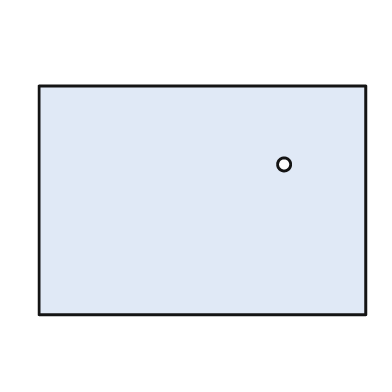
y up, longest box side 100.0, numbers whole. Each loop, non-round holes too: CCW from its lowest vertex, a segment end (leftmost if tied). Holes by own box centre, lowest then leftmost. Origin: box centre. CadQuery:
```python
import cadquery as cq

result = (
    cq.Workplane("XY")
    .moveTo(-50.0, -35.0)
    .lineTo(50.0, -35.0)
    .lineTo(50.0, 35.0)
    .lineTo(-50.0, 35.0)
    .close()
    .moveTo(25.0, 11.0)
    .circle(2.0)
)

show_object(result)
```